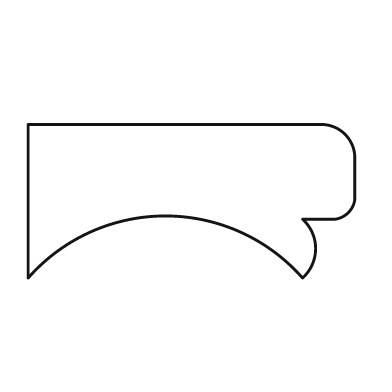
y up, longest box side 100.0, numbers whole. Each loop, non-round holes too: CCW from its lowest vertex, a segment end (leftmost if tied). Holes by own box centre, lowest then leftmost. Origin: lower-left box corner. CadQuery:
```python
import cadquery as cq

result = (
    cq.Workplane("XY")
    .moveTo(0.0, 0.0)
    .threePointArc((42.0, 19.0), (84.0, 0.0))
    .threePointArc((88.0, 9.0), (84.0, 18.0))
    .lineTo(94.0, 18.0)
    .threePointArc((98.0, 20.0), (100.0, 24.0))
    .lineTo(100.0, 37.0)
    .threePointArc((97.0, 44.0), (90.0, 47.0))
    .lineTo(0.0, 47.0)
    .close()
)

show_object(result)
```